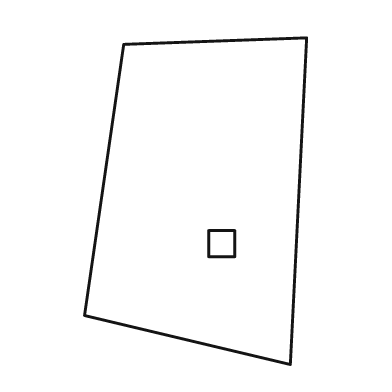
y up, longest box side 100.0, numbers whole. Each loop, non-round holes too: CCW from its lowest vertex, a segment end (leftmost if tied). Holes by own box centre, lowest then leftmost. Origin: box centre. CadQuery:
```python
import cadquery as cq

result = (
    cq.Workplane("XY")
    .moveTo(29.0, -50.0)
    .lineTo(34.0, 50.0)
    .lineTo(-22.0, 48.0)
    .lineTo(-34.0, -35.0)
    .close()
    .moveTo(4.0, -17.0)
    .lineTo(12.0, -17.0)
    .lineTo(12.0, -9.0)
    .lineTo(4.0, -9.0)
    .close()
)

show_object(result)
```